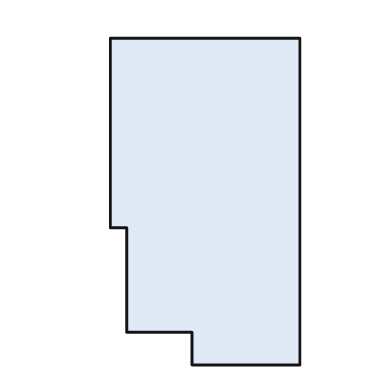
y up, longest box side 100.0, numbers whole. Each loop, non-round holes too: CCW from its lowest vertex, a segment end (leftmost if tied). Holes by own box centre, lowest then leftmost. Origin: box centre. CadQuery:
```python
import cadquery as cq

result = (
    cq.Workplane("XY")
    .moveTo(-4.0, -50.0)
    .lineTo(29.0, -50.0)
    .lineTo(29.0, 50.0)
    .lineTo(-29.0, 50.0)
    .lineTo(-29.0, -8.0)
    .lineTo(-24.0, -8.0)
    .lineTo(-24.0, -40.0)
    .lineTo(-4.0, -40.0)
    .close()
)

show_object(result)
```